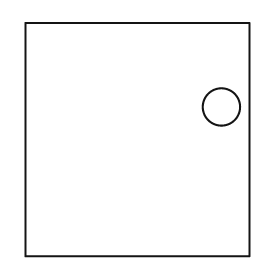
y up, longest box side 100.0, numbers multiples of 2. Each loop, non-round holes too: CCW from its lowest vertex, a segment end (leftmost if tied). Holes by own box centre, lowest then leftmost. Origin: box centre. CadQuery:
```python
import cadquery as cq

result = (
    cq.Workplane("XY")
    .moveTo(-48.0, -50.0)
    .lineTo(48.0, -50.0)
    .lineTo(48.0, 50.0)
    .lineTo(-48.0, 50.0)
    .close()
    .moveTo(36.0, 14.0)
    .circle(8.0)
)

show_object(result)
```